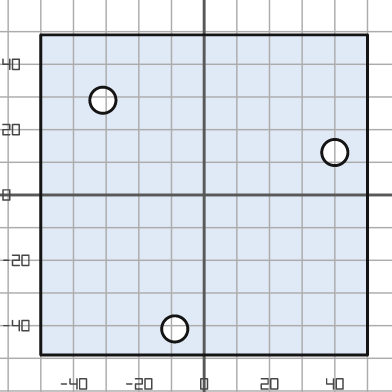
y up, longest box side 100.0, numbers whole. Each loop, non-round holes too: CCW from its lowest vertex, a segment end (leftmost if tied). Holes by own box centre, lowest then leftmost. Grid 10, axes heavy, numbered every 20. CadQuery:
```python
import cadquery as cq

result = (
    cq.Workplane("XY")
    .moveTo(-50.0, -49.0)
    .lineTo(50.0, -49.0)
    .lineTo(50.0, 49.0)
    .lineTo(-50.0, 49.0)
    .close()
    .moveTo(-9.0, -41.0)
    .circle(4.0)
    .moveTo(40.0, 13.0)
    .circle(4.0)
    .moveTo(-31.0, 29.0)
    .circle(4.0)
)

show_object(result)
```